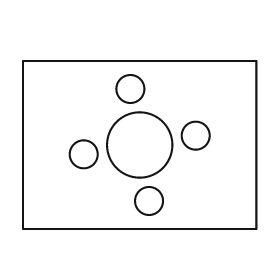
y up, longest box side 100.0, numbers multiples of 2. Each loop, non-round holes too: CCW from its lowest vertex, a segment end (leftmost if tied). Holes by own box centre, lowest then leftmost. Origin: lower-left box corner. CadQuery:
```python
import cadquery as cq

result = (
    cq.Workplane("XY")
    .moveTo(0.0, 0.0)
    .lineTo(100.0, 0.0)
    .lineTo(100.0, 72.0)
    .lineTo(0.0, 72.0)
    .close()
    .moveTo(54.0, 12.0)
    .circle(6.0)
    .moveTo(26.0, 32.0)
    .circle(6.0)
    .moveTo(50.0, 36.0)
    .circle(14.0)
    .moveTo(74.0, 40.0)
    .circle(6.0)
    .moveTo(46.0, 60.0)
    .circle(6.0)
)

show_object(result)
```